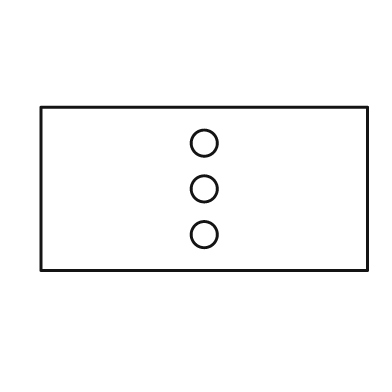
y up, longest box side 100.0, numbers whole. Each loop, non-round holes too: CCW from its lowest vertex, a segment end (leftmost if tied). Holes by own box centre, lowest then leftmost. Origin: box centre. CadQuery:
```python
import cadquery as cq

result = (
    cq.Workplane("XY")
    .moveTo(-50.0, -25.0)
    .lineTo(50.0, -25.0)
    .lineTo(50.0, 25.0)
    .lineTo(-50.0, 25.0)
    .close()
    .moveTo(0.0, -14.0)
    .circle(4.0)
    .moveTo(0.0, 0.0)
    .circle(4.0)
    .moveTo(0.0, 14.0)
    .circle(4.0)
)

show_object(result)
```